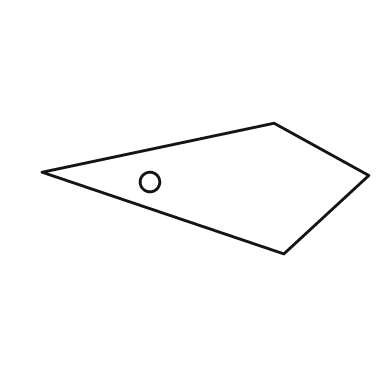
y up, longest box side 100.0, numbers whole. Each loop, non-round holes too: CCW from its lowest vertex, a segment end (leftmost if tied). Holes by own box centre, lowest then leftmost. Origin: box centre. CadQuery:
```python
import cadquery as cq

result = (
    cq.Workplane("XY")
    .moveTo(24.0, -20.0)
    .lineTo(50.0, 4.0)
    .lineTo(21.0, 20.0)
    .lineTo(-50.0, 5.0)
    .close()
    .moveTo(-17.0, 2.0)
    .circle(3.0)
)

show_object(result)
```